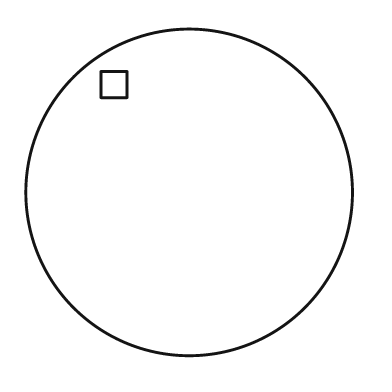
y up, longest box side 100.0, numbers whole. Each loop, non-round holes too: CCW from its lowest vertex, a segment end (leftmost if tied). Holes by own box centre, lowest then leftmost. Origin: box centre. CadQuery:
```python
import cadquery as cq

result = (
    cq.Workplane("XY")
    .moveTo(0.0, 0.0)
    .circle(50.0)
    .moveTo(-27.0, 29.0)
    .lineTo(-19.0, 29.0)
    .lineTo(-19.0, 37.0)
    .lineTo(-27.0, 37.0)
    .close()
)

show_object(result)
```